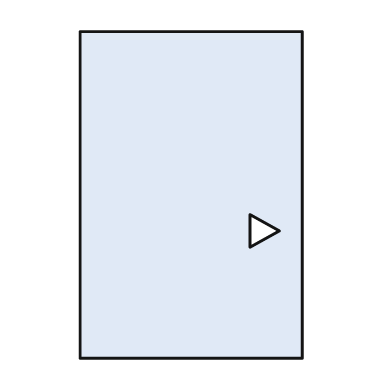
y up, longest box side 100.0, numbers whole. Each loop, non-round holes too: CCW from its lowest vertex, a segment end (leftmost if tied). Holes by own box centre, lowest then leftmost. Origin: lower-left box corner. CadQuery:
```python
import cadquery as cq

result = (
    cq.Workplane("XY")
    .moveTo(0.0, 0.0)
    .lineTo(68.0, 0.0)
    .lineTo(68.0, 100.0)
    .lineTo(0.0, 100.0)
    .close()
    .moveTo(52.0, 34.0)
    .lineTo(61.0, 39.0)
    .lineTo(52.0, 44.0)
    .close()
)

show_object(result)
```